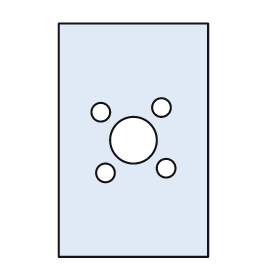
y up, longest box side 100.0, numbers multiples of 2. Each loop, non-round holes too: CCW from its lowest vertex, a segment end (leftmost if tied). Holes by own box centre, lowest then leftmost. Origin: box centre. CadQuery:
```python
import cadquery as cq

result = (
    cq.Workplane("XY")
    .moveTo(-32.0, -50.0)
    .lineTo(32.0, -50.0)
    .lineTo(32.0, 50.0)
    .lineTo(-32.0, 50.0)
    .close()
    .moveTo(-12.0, -14.0)
    .circle(4.0)
    .moveTo(14.0, -12.0)
    .circle(4.0)
    .moveTo(0.0, 0.0)
    .circle(10.0)
    .moveTo(-14.0, 12.0)
    .circle(4.0)
    .moveTo(12.0, 14.0)
    .circle(4.0)
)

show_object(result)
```